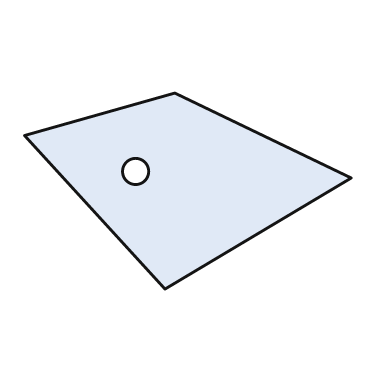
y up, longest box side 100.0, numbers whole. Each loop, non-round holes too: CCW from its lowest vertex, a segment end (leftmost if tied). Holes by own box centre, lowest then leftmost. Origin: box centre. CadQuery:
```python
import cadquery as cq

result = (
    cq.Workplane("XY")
    .moveTo(-7.0, -30.0)
    .lineTo(50.0, 4.0)
    .lineTo(-4.0, 30.0)
    .lineTo(-50.0, 17.0)
    .close()
    .moveTo(-16.0, 6.0)
    .circle(4.0)
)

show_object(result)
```